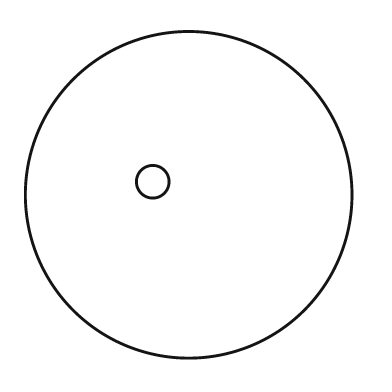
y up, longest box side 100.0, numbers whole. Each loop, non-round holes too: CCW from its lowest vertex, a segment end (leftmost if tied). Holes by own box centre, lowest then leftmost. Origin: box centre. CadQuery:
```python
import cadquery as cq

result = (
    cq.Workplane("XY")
    .moveTo(0.0, 0.0)
    .circle(50.0)
    .moveTo(-11.0, 4.0)
    .circle(5.0)
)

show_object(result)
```